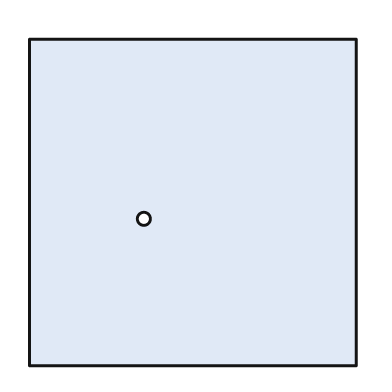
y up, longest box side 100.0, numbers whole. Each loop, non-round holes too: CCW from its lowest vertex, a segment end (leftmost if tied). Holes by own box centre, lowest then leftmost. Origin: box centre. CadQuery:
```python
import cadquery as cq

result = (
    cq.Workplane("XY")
    .moveTo(-50.0, -50.0)
    .lineTo(50.0, -50.0)
    .lineTo(50.0, 50.0)
    .lineTo(-50.0, 50.0)
    .close()
    .moveTo(-15.0, -5.0)
    .circle(2.0)
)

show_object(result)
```